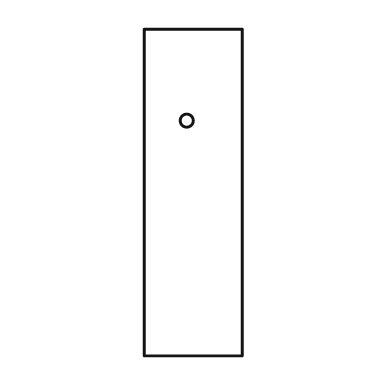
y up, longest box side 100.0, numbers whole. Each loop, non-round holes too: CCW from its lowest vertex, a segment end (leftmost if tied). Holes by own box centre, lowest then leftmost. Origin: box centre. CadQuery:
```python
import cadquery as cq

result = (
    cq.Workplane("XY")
    .moveTo(-15.0, -50.0)
    .lineTo(15.0, -50.0)
    .lineTo(15.0, 50.0)
    .lineTo(-15.0, 50.0)
    .close()
    .moveTo(-2.0, 22.0)
    .circle(2.0)
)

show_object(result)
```